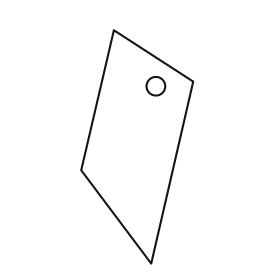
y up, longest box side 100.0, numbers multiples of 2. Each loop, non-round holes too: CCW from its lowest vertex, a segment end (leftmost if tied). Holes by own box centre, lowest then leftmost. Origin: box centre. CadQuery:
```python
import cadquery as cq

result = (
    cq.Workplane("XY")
    .moveTo(6.0, -50.0)
    .lineTo(24.0, 28.0)
    .lineTo(-10.0, 50.0)
    .lineTo(-24.0, -10.0)
    .close()
    .moveTo(8.0, 26.0)
    .circle(4.0)
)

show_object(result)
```